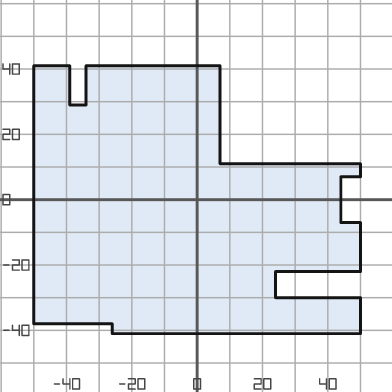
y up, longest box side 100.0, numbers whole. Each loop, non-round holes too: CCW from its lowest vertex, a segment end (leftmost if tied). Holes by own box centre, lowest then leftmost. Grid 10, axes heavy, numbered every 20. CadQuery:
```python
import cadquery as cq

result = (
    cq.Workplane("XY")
    .moveTo(-26.0, -41.0)
    .lineTo(50.0, -41.0)
    .lineTo(50.0, -30.0)
    .lineTo(24.0, -30.0)
    .lineTo(24.0, -22.0)
    .lineTo(50.0, -22.0)
    .lineTo(50.0, -7.0)
    .lineTo(44.0, -7.0)
    .lineTo(44.0, 7.0)
    .lineTo(50.0, 7.0)
    .lineTo(50.0, 11.0)
    .lineTo(7.0, 11.0)
    .lineTo(7.0, 41.0)
    .lineTo(-34.0, 41.0)
    .lineTo(-34.0, 29.0)
    .lineTo(-39.0, 29.0)
    .lineTo(-39.0, 41.0)
    .lineTo(-50.0, 41.0)
    .lineTo(-50.0, -38.0)
    .lineTo(-26.0, -38.0)
    .close()
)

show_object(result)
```